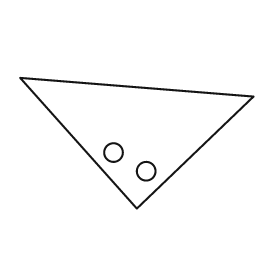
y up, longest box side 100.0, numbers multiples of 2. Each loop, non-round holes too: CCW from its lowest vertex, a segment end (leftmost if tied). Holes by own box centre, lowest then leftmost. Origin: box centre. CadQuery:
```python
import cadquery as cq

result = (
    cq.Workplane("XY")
    .moveTo(0.0, -28.0)
    .lineTo(50.0, 20.0)
    .lineTo(-50.0, 28.0)
    .close()
    .moveTo(4.0, -12.0)
    .circle(4.0)
    .moveTo(-10.0, -4.0)
    .circle(4.0)
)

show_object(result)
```